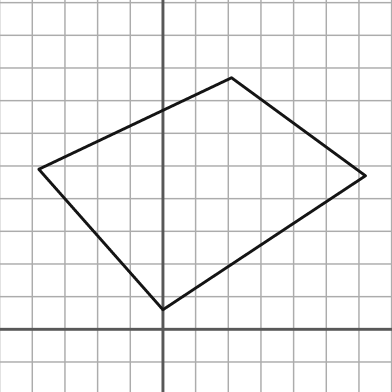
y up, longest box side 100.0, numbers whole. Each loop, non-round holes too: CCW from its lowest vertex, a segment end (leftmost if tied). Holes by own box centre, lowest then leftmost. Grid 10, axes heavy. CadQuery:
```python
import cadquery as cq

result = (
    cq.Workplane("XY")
    .moveTo(0.0, 6.0)
    .lineTo(62.0, 47.0)
    .lineTo(21.0, 77.0)
    .lineTo(-38.0, 49.0)
    .close()
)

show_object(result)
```